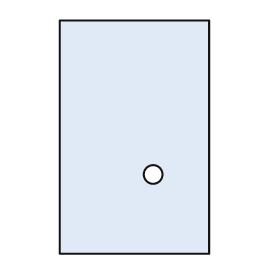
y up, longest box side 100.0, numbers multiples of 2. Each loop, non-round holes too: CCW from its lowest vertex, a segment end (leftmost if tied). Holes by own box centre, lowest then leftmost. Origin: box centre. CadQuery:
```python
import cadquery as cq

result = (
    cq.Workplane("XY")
    .moveTo(-32.0, -50.0)
    .lineTo(32.0, -50.0)
    .lineTo(32.0, 50.0)
    .lineTo(-32.0, 50.0)
    .close()
    .moveTo(8.0, -16.0)
    .circle(4.0)
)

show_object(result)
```